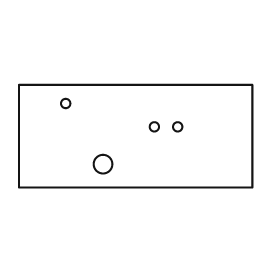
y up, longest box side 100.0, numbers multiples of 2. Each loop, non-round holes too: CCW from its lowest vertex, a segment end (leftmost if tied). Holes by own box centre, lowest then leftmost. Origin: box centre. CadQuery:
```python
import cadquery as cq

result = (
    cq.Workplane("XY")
    .moveTo(-50.0, -22.0)
    .lineTo(50.0, -22.0)
    .lineTo(50.0, 22.0)
    .lineTo(-50.0, 22.0)
    .close()
    .moveTo(-14.0, -12.0)
    .circle(4.0)
    .moveTo(8.0, 4.0)
    .circle(2.0)
    .moveTo(18.0, 4.0)
    .circle(2.0)
    .moveTo(-30.0, 14.0)
    .circle(2.0)
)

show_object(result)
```